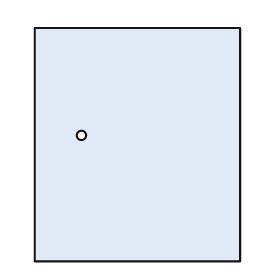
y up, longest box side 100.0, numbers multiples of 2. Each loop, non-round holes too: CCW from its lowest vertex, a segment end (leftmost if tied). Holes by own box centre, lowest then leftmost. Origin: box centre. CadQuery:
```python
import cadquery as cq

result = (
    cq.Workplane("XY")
    .moveTo(-44.0, -50.0)
    .lineTo(44.0, -50.0)
    .lineTo(44.0, 50.0)
    .lineTo(-44.0, 50.0)
    .close()
    .moveTo(-24.0, 4.0)
    .circle(2.0)
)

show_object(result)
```